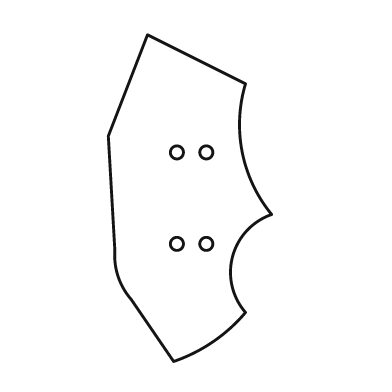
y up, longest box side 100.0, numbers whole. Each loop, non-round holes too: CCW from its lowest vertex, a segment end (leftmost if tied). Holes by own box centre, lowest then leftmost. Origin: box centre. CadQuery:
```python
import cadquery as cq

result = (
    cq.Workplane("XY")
    .moveTo(-5.0, -50.0)
    .threePointArc((7.0, -44.0), (17.0, -35.0))
    .threePointArc((13.0, -18.0), (25.0, -5.0))
    .threePointArc((16.0, 14.0), (17.0, 35.0))
    .lineTo(-13.0, 50.0)
    .lineTo(-25.0, 19.0)
    .lineTo(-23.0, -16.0)
    .threePointArc((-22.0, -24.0), (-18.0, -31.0))
    .close()
    .moveTo(-4.0, -14.0)
    .circle(2.0)
    .moveTo(5.0, -14.0)
    .circle(2.0)
    .moveTo(-4.0, 14.0)
    .circle(2.0)
    .moveTo(5.0, 14.0)
    .circle(2.0)
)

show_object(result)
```